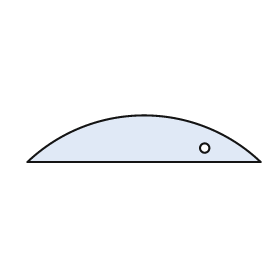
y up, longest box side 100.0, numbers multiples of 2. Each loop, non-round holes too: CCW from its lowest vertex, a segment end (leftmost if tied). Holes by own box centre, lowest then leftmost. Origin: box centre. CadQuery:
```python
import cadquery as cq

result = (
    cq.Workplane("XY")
    .moveTo(-50.0, -10.0)
    .lineTo(50.0, -10.0)
    .threePointArc((0.0, 10.0), (-50.0, -10.0))
    .close()
    .moveTo(26.0, -4.0)
    .circle(2.0)
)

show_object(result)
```